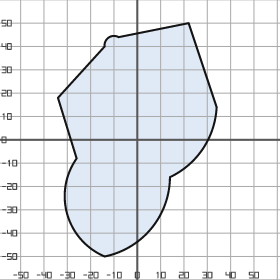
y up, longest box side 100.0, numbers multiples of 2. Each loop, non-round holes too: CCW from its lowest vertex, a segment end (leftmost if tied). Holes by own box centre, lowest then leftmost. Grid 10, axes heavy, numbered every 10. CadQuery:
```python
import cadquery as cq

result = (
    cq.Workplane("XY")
    .moveTo(-14.0, -50.0)
    .threePointArc((6.0, -38.0), (14.0, -16.0))
    .threePointArc((28.0, -4.0), (34.0, 14.0))
    .lineTo(22.0, 50.0)
    .lineTo(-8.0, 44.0)
    .threePointArc((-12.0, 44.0), (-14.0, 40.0))
    .lineTo(-34.0, 18.0)
    .lineTo(-26.0, -8.0)
    .threePointArc((-30.0, -32.0), (-14.0, -50.0))
    .close()
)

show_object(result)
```